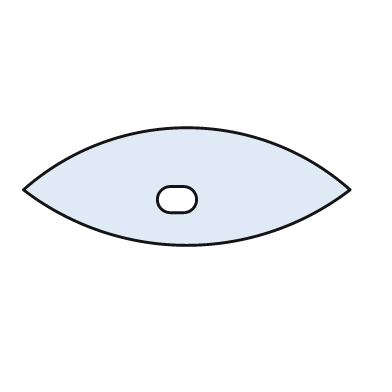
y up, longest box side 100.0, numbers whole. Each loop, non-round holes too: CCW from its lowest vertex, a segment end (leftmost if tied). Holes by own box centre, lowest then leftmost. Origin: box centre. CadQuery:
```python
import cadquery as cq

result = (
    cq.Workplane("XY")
    .moveTo(-50.0, -1.0)
    .threePointArc((0.0, -18.0), (50.0, -1.0))
    .threePointArc((0.0, 18.0), (-50.0, -1.0))
    .close()
    .moveTo(-5.0, -8.0)
    .lineTo(-1.0, -8.0)
    .threePointArc((3.0, -4.0), (-1.0, 0.0))
    .lineTo(-5.0, 0.0)
    .threePointArc((-9.0, -4.0), (-5.0, -8.0))
    .close()
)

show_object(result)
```